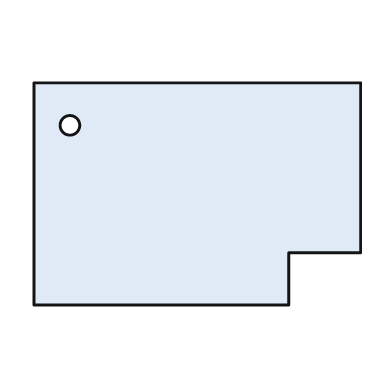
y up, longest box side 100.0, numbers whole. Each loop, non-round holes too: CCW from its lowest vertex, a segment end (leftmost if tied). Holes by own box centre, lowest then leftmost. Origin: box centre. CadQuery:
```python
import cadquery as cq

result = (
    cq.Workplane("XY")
    .moveTo(-50.0, -34.0)
    .lineTo(28.0, -34.0)
    .lineTo(28.0, -18.0)
    .lineTo(50.0, -18.0)
    .lineTo(50.0, 34.0)
    .lineTo(-50.0, 34.0)
    .close()
    .moveTo(-39.0, 21.0)
    .circle(3.0)
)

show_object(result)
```